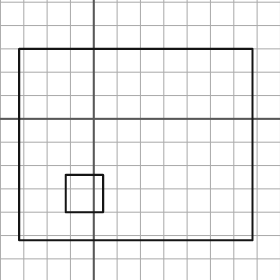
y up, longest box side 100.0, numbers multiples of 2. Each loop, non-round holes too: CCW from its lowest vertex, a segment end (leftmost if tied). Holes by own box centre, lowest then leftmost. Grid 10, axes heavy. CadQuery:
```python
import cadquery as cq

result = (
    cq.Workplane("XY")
    .moveTo(-32.0, -52.0)
    .lineTo(68.0, -52.0)
    .lineTo(68.0, 30.0)
    .lineTo(-32.0, 30.0)
    .close()
    .moveTo(-12.0, -40.0)
    .lineTo(4.0, -40.0)
    .lineTo(4.0, -24.0)
    .lineTo(-12.0, -24.0)
    .close()
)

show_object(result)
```